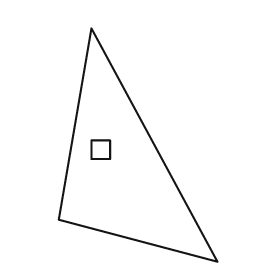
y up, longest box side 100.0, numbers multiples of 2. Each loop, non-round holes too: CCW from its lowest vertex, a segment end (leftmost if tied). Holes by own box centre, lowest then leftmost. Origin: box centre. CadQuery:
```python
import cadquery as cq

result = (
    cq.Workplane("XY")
    .moveTo(34.0, -50.0)
    .lineTo(-20.0, 50.0)
    .lineTo(-34.0, -32.0)
    .close()
    .moveTo(-20.0, -6.0)
    .lineTo(-12.0, -6.0)
    .lineTo(-12.0, 2.0)
    .lineTo(-20.0, 2.0)
    .close()
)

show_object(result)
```